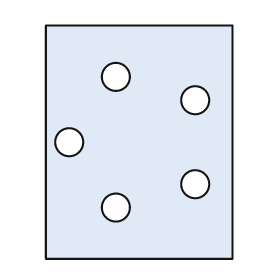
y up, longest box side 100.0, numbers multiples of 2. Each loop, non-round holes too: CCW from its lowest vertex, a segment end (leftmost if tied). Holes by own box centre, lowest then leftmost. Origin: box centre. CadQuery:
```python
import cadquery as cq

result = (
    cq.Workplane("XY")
    .moveTo(-40.0, -50.0)
    .lineTo(40.0, -50.0)
    .lineTo(40.0, 50.0)
    .lineTo(-40.0, 50.0)
    .close()
    .moveTo(-10.0, -28.0)
    .circle(6.0)
    .moveTo(24.0, -18.0)
    .circle(6.0)
    .moveTo(-30.0, 0.0)
    .circle(6.0)
    .moveTo(24.0, 18.0)
    .circle(6.0)
    .moveTo(-10.0, 28.0)
    .circle(6.0)
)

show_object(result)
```